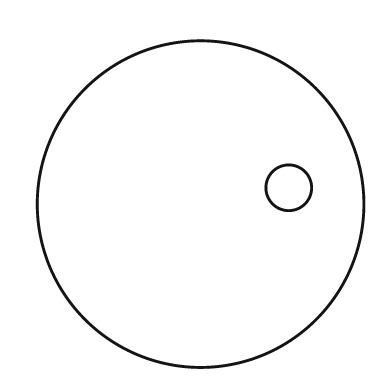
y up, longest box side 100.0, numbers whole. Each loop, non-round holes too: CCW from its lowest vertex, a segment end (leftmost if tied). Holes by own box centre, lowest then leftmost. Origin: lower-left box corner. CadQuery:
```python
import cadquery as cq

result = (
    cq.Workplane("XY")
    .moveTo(50.0, 50.0)
    .circle(50.0)
    .moveTo(77.0, 55.0)
    .circle(7.0)
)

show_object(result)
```